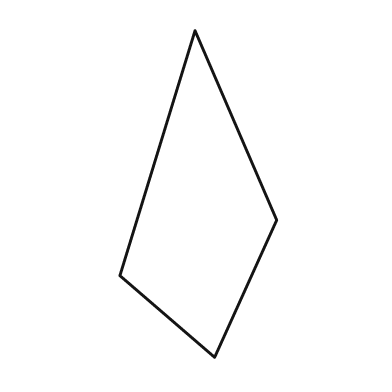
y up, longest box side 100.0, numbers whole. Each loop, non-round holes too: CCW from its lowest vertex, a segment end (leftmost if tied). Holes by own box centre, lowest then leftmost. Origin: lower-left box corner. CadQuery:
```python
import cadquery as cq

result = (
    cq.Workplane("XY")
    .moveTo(29.0, 0.0)
    .lineTo(48.0, 42.0)
    .lineTo(23.0, 100.0)
    .lineTo(0.0, 25.0)
    .close()
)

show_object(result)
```